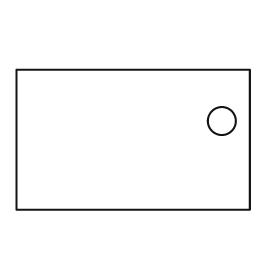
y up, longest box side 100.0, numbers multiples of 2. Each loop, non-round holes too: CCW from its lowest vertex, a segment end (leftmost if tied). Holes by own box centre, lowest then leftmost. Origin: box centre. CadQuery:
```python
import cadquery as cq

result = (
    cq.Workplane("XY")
    .moveTo(-50.0, -30.0)
    .lineTo(50.0, -30.0)
    .lineTo(50.0, 30.0)
    .lineTo(-50.0, 30.0)
    .close()
    .moveTo(38.0, 8.0)
    .circle(6.0)
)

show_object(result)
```